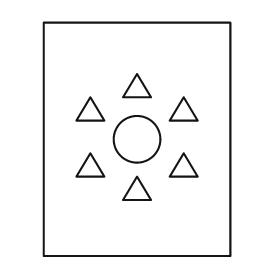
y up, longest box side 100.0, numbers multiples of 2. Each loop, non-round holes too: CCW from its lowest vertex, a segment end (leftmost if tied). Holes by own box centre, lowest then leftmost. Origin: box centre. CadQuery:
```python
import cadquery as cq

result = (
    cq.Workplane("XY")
    .moveTo(-40.0, -50.0)
    .lineTo(40.0, -50.0)
    .lineTo(40.0, 50.0)
    .lineTo(-40.0, 50.0)
    .close()
    .moveTo(-6.0, -26.0)
    .lineTo(6.0, -26.0)
    .lineTo(0.0, -16.0)
    .close()
    .moveTo(-26.0, -16.0)
    .lineTo(-14.0, -16.0)
    .lineTo(-20.0, -6.0)
    .close()
    .moveTo(14.0, -16.0)
    .lineTo(26.0, -16.0)
    .lineTo(20.0, -6.0)
    .close()
    .moveTo(0.0, 0.0)
    .circle(10.0)
    .moveTo(-26.0, 8.0)
    .lineTo(-14.0, 8.0)
    .lineTo(-20.0, 18.0)
    .close()
    .moveTo(14.0, 8.0)
    .lineTo(26.0, 8.0)
    .lineTo(20.0, 18.0)
    .close()
    .moveTo(-6.0, 18.0)
    .lineTo(6.0, 18.0)
    .lineTo(0.0, 28.0)
    .close()
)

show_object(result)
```